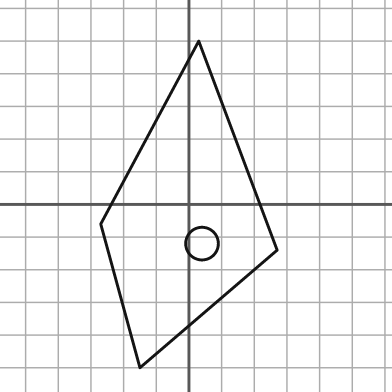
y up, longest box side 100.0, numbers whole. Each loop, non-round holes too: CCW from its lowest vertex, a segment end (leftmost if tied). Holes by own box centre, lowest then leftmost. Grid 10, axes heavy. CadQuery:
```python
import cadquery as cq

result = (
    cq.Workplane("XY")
    .moveTo(-15.0, -50.0)
    .lineTo(27.0, -14.0)
    .lineTo(3.0, 50.0)
    .lineTo(-27.0, -6.0)
    .close()
    .moveTo(4.0, -12.0)
    .circle(5.0)
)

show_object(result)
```